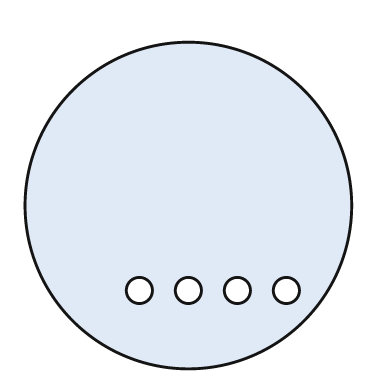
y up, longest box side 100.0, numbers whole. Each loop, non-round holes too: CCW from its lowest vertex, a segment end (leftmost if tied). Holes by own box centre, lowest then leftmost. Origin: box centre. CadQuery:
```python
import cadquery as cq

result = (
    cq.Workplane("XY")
    .moveTo(0.0, 0.0)
    .circle(50.0)
    .moveTo(-15.0, -26.0)
    .circle(4.0)
    .moveTo(0.0, -26.0)
    .circle(4.0)
    .moveTo(15.0, -26.0)
    .circle(4.0)
    .moveTo(30.0, -26.0)
    .circle(4.0)
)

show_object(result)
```